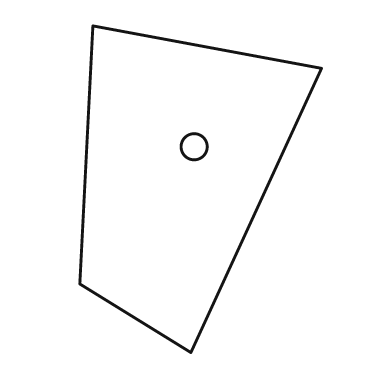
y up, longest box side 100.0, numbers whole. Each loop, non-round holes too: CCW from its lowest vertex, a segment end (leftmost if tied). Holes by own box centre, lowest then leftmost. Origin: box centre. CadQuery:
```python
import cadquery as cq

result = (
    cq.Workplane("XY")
    .moveTo(-3.0, -50.0)
    .lineTo(37.0, 37.0)
    .lineTo(-33.0, 50.0)
    .lineTo(-37.0, -29.0)
    .close()
    .moveTo(-2.0, 13.0)
    .circle(4.0)
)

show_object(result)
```